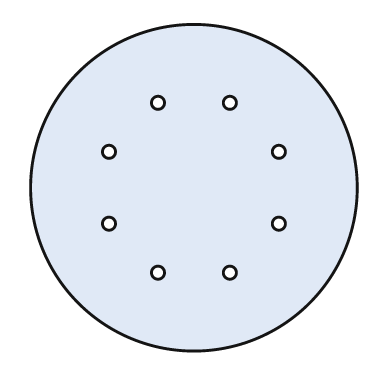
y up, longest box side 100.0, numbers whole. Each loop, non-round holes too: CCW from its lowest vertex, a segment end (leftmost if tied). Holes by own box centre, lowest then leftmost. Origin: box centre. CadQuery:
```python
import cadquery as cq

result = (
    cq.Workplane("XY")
    .moveTo(0.0, 0.0)
    .circle(50.0)
    .moveTo(-11.0, -26.0)
    .circle(2.0)
    .moveTo(11.0, -26.0)
    .circle(2.0)
    .moveTo(-26.0, -11.0)
    .circle(2.0)
    .moveTo(26.0, -11.0)
    .circle(2.0)
    .moveTo(-26.0, 11.0)
    .circle(2.0)
    .moveTo(26.0, 11.0)
    .circle(2.0)
    .moveTo(-11.0, 26.0)
    .circle(2.0)
    .moveTo(11.0, 26.0)
    .circle(2.0)
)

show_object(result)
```